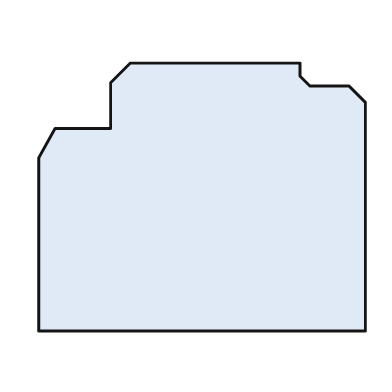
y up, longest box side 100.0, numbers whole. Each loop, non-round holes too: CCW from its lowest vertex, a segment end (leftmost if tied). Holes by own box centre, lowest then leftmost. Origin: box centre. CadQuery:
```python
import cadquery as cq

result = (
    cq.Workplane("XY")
    .moveTo(-50.0, -41.0)
    .lineTo(50.0, -41.0)
    .lineTo(50.0, 29.0)
    .lineTo(45.0, 34.0)
    .lineTo(33.0, 34.0)
    .lineTo(30.0, 37.0)
    .lineTo(30.0, 41.0)
    .lineTo(-22.0, 41.0)
    .lineTo(-28.0, 35.0)
    .lineTo(-28.0, 21.0)
    .lineTo(-45.0, 21.0)
    .lineTo(-50.0, 12.0)
    .close()
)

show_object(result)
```